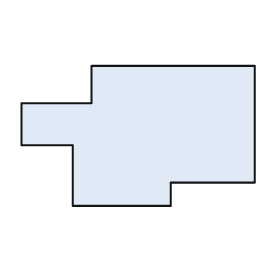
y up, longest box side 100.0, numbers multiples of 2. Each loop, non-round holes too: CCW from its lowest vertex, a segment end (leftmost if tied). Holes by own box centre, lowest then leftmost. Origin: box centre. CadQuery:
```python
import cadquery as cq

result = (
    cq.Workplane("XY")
    .moveTo(-28.0, -30.0)
    .lineTo(14.0, -30.0)
    .lineTo(14.0, -20.0)
    .lineTo(50.0, -20.0)
    .lineTo(50.0, 30.0)
    .lineTo(-20.0, 30.0)
    .lineTo(-20.0, 14.0)
    .lineTo(-50.0, 14.0)
    .lineTo(-50.0, -4.0)
    .lineTo(-28.0, -4.0)
    .close()
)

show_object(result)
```